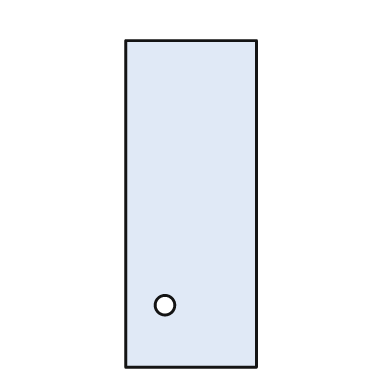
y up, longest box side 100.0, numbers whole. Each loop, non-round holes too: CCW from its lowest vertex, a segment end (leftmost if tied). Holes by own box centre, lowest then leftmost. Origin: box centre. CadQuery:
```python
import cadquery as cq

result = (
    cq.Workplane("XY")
    .moveTo(-20.0, -50.0)
    .lineTo(20.0, -50.0)
    .lineTo(20.0, 50.0)
    .lineTo(-20.0, 50.0)
    .close()
    .moveTo(-8.0, -31.0)
    .circle(3.0)
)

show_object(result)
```